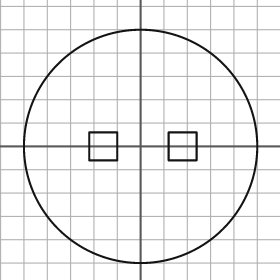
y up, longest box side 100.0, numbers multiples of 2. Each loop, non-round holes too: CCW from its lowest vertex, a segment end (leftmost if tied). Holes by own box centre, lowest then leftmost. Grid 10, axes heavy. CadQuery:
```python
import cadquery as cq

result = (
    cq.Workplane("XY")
    .moveTo(0.0, 0.0)
    .circle(50.0)
    .moveTo(-22.0, -6.0)
    .lineTo(-10.0, -6.0)
    .lineTo(-10.0, 6.0)
    .lineTo(-22.0, 6.0)
    .close()
    .moveTo(12.0, -6.0)
    .lineTo(24.0, -6.0)
    .lineTo(24.0, 6.0)
    .lineTo(12.0, 6.0)
    .close()
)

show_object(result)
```